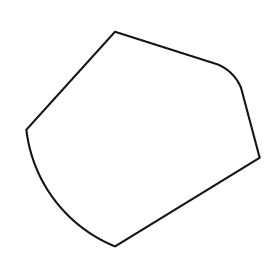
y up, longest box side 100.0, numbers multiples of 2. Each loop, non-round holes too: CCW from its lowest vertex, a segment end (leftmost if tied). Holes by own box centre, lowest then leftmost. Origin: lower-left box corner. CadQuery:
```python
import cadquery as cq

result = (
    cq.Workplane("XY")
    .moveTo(38.0, 0.0)
    .lineTo(100.0, 38.0)
    .lineTo(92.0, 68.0)
    .threePointArc((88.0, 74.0), (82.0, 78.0))
    .lineTo(38.0, 92.0)
    .lineTo(0.0, 50.0)
    .threePointArc((12.0, 20.0), (38.0, 0.0))
    .close()
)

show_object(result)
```